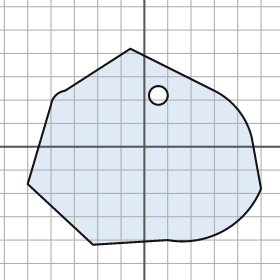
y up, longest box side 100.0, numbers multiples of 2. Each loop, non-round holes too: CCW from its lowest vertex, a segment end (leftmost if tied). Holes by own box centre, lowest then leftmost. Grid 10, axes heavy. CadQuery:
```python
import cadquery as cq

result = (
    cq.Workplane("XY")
    .moveTo(-22.0, -42.0)
    .lineTo(10.0, -40.0)
    .threePointArc((34.0, -36.0), (50.0, -18.0))
    .lineTo(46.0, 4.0)
    .threePointArc((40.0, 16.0), (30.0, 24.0))
    .lineTo(-6.0, 42.0)
    .lineTo(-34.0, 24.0)
    .threePointArc((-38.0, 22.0), (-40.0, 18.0))
    .lineTo(-50.0, -16.0)
    .close()
    .moveTo(6.0, 22.0)
    .circle(4.0)
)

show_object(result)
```